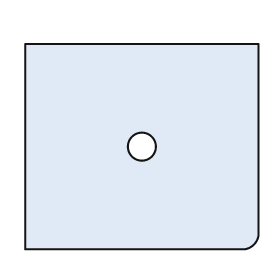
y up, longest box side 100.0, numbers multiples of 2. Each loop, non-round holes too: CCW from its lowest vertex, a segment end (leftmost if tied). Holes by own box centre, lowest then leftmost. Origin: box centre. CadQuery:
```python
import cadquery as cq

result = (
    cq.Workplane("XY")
    .moveTo(-50.0, -44.0)
    .lineTo(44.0, -44.0)
    .threePointArc((48.0, -42.0), (50.0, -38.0))
    .lineTo(50.0, 44.0)
    .lineTo(-50.0, 44.0)
    .close()
    .moveTo(0.0, 0.0)
    .circle(6.0)
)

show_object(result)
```